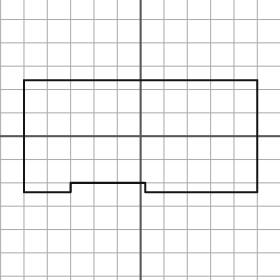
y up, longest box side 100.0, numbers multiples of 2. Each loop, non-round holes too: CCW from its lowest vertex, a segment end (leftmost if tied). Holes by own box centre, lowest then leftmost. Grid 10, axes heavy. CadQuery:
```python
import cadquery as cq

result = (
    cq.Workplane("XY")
    .moveTo(-50.0, -24.0)
    .lineTo(-30.0, -24.0)
    .lineTo(-30.0, -20.0)
    .lineTo(2.0, -20.0)
    .lineTo(2.0, -24.0)
    .lineTo(50.0, -24.0)
    .lineTo(50.0, 24.0)
    .lineTo(-50.0, 24.0)
    .close()
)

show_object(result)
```